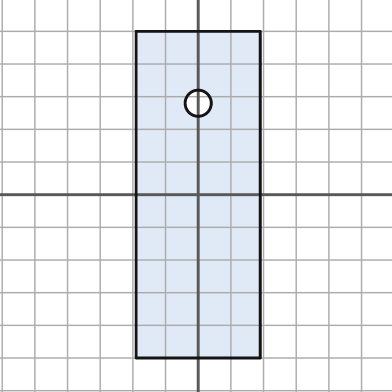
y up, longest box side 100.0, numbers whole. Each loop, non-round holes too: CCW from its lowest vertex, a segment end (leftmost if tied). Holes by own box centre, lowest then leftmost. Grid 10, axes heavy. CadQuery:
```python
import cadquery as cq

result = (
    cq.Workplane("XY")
    .moveTo(-19.0, -50.0)
    .lineTo(19.0, -50.0)
    .lineTo(19.0, 50.0)
    .lineTo(-19.0, 50.0)
    .close()
    .moveTo(0.0, 28.0)
    .circle(4.0)
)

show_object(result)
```